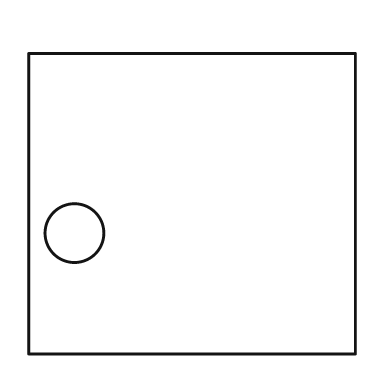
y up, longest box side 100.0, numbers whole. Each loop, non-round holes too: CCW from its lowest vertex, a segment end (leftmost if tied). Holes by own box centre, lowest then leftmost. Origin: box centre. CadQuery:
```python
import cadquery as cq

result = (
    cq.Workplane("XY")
    .moveTo(-50.0, -46.0)
    .lineTo(50.0, -46.0)
    .lineTo(50.0, 46.0)
    .lineTo(-50.0, 46.0)
    .close()
    .moveTo(-36.0, -9.0)
    .circle(9.0)
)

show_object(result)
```